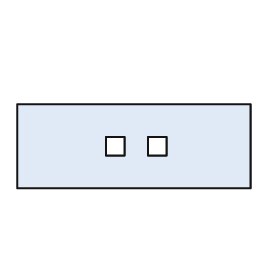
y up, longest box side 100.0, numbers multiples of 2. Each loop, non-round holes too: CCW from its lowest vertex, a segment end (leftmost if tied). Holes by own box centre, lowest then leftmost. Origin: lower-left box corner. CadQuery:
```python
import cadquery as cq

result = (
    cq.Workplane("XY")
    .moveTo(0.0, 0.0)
    .lineTo(100.0, 0.0)
    .lineTo(100.0, 36.0)
    .lineTo(0.0, 36.0)
    .close()
    .moveTo(38.0, 14.0)
    .lineTo(46.0, 14.0)
    .lineTo(46.0, 22.0)
    .lineTo(38.0, 22.0)
    .close()
    .moveTo(56.0, 14.0)
    .lineTo(64.0, 14.0)
    .lineTo(64.0, 22.0)
    .lineTo(56.0, 22.0)
    .close()
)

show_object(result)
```